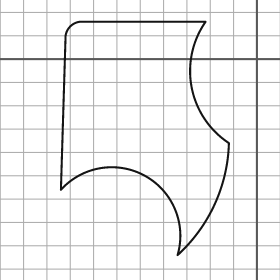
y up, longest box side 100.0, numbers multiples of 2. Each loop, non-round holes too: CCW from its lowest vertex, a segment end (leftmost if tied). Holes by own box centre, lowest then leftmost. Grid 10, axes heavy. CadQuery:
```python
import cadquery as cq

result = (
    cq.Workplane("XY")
    .moveTo(-34.0, -84.0)
    .threePointArc((-18.0, -62.0), (-12.0, -36.0))
    .threePointArc((-28.0, -12.0), (-22.0, 16.0))
    .lineTo(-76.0, 16.0)
    .threePointArc((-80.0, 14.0), (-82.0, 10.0))
    .lineTo(-84.0, -56.0)
    .threePointArc((-48.0, -50.0), (-34.0, -84.0))
    .close()
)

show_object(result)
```